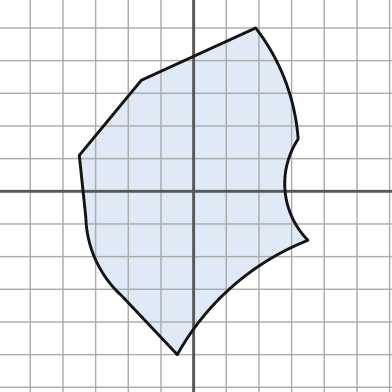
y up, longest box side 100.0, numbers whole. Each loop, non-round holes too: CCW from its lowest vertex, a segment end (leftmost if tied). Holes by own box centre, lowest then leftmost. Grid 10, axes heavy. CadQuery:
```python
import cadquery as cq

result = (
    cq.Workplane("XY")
    .moveTo(-5.0, -50.0)
    .threePointArc((12.0, -29.0), (35.0, -15.0))
    .threePointArc((28.0, 0.0), (32.0, 16.0))
    .threePointArc((28.0, 34.0), (19.0, 50.0))
    .lineTo(-16.0, 34.0)
    .lineTo(-35.0, 11.0)
    .lineTo(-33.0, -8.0)
    .threePointArc((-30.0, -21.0), (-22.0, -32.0))
    .close()
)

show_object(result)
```